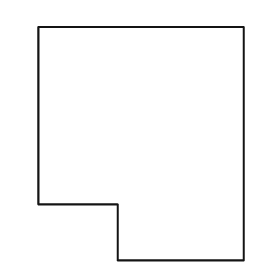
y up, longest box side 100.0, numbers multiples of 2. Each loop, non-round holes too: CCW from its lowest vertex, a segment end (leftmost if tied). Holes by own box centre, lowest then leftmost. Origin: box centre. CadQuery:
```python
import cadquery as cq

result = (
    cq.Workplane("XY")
    .moveTo(-10.0, -50.0)
    .lineTo(44.0, -50.0)
    .lineTo(44.0, 50.0)
    .lineTo(-44.0, 50.0)
    .lineTo(-44.0, -26.0)
    .lineTo(-10.0, -26.0)
    .close()
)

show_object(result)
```